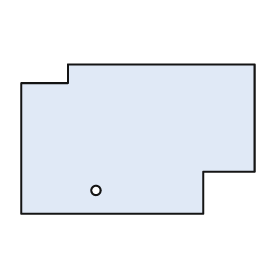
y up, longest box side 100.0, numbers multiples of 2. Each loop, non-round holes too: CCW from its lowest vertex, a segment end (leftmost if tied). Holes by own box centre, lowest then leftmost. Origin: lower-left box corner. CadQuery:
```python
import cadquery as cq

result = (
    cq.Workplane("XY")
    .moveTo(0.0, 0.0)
    .lineTo(78.0, 0.0)
    .lineTo(78.0, 18.0)
    .lineTo(100.0, 18.0)
    .lineTo(100.0, 64.0)
    .lineTo(20.0, 64.0)
    .lineTo(20.0, 56.0)
    .lineTo(0.0, 56.0)
    .close()
    .moveTo(32.0, 10.0)
    .circle(2.0)
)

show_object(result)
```